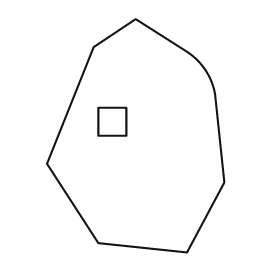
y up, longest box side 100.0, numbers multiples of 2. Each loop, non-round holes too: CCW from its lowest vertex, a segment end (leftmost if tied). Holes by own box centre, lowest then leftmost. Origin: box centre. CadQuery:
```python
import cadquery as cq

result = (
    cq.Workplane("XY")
    .moveTo(22.0, -50.0)
    .lineTo(38.0, -20.0)
    .lineTo(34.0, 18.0)
    .threePointArc((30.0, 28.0), (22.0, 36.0))
    .lineTo(0.0, 50.0)
    .lineTo(-18.0, 38.0)
    .lineTo(-38.0, -12.0)
    .lineTo(-16.0, -46.0)
    .close()
    .moveTo(-16.0, 0.0)
    .lineTo(-4.0, 0.0)
    .lineTo(-4.0, 12.0)
    .lineTo(-16.0, 12.0)
    .close()
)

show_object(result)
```